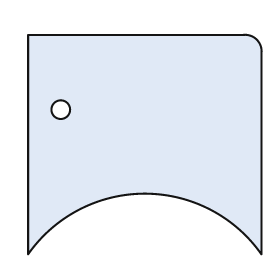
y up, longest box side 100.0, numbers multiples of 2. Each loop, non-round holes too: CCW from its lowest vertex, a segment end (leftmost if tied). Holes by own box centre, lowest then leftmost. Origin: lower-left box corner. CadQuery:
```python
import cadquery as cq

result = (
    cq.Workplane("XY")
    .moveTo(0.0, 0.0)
    .threePointArc((50.0, 26.0), (100.0, 0.0))
    .lineTo(100.0, 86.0)
    .threePointArc((98.0, 92.0), (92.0, 94.0))
    .lineTo(0.0, 94.0)
    .close()
    .moveTo(14.0, 62.0)
    .circle(4.0)
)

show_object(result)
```